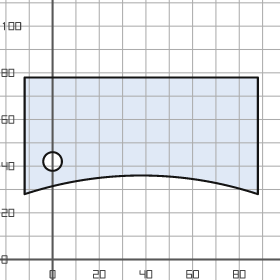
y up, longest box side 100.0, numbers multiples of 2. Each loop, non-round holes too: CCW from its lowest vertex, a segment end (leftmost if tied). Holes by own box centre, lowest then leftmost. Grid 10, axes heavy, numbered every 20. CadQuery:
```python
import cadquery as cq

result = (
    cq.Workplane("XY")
    .moveTo(-12.0, 28.0)
    .threePointArc((38.0, 36.0), (88.0, 28.0))
    .lineTo(88.0, 78.0)
    .lineTo(-12.0, 78.0)
    .close()
    .moveTo(0.0, 42.0)
    .circle(4.0)
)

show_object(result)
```